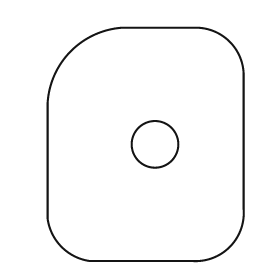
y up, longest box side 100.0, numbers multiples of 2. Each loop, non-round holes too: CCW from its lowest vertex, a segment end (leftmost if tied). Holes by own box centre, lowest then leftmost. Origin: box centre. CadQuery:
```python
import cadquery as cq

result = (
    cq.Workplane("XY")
    .moveTo(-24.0, -50.0)
    .lineTo(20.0, -50.0)
    .threePointArc((36.0, -44.0), (42.0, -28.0))
    .lineTo(42.0, 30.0)
    .threePointArc((36.0, 44.0), (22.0, 50.0))
    .lineTo(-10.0, 50.0)
    .threePointArc((-32.0, 40.0), (-42.0, 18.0))
    .lineTo(-42.0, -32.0)
    .threePointArc((-36.0, -44.0), (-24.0, -50.0))
    .close()
    .moveTo(4.0, 0.0)
    .circle(10.0)
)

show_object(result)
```